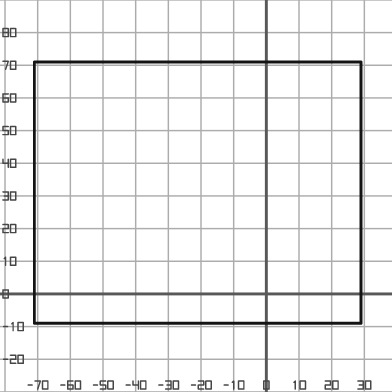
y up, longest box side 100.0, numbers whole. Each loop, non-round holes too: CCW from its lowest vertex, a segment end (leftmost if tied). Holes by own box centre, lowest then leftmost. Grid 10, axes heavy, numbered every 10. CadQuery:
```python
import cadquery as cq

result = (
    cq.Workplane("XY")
    .moveTo(-71.0, -9.0)
    .lineTo(29.0, -9.0)
    .lineTo(29.0, 71.0)
    .lineTo(-71.0, 71.0)
    .close()
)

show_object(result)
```